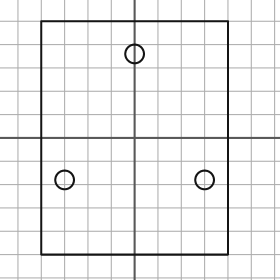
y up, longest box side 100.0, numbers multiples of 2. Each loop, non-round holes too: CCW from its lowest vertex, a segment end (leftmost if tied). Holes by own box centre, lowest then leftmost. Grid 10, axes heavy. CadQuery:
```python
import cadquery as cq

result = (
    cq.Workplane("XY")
    .moveTo(-40.0, -50.0)
    .lineTo(40.0, -50.0)
    .lineTo(40.0, 50.0)
    .lineTo(-40.0, 50.0)
    .close()
    .moveTo(-30.0, -18.0)
    .circle(4.0)
    .moveTo(30.0, -18.0)
    .circle(4.0)
    .moveTo(0.0, 36.0)
    .circle(4.0)
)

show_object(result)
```